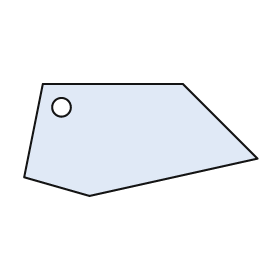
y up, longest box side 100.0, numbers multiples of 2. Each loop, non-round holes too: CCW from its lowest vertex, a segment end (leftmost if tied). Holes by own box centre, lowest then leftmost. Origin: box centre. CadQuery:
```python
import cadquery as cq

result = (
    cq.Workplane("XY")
    .moveTo(-22.0, -24.0)
    .lineTo(50.0, -8.0)
    .lineTo(18.0, 24.0)
    .lineTo(-42.0, 24.0)
    .lineTo(-50.0, -16.0)
    .close()
    .moveTo(-34.0, 14.0)
    .circle(4.0)
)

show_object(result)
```